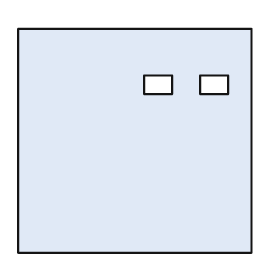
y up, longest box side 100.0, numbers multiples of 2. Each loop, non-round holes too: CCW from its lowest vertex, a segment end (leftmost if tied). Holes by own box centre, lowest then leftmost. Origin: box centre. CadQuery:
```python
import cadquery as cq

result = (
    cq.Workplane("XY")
    .moveTo(-50.0, -48.0)
    .lineTo(50.0, -48.0)
    .lineTo(50.0, 48.0)
    .lineTo(-50.0, 48.0)
    .close()
    .moveTo(4.0, 20.0)
    .lineTo(16.0, 20.0)
    .lineTo(16.0, 28.0)
    .lineTo(4.0, 28.0)
    .close()
    .moveTo(28.0, 20.0)
    .lineTo(40.0, 20.0)
    .lineTo(40.0, 28.0)
    .lineTo(28.0, 28.0)
    .close()
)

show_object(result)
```